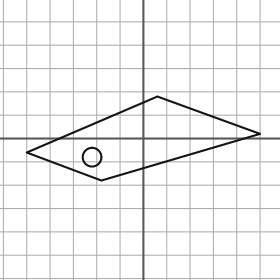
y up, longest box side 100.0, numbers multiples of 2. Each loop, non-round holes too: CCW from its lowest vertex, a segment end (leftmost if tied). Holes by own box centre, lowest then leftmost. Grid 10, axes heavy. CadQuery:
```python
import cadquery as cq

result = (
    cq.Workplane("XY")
    .moveTo(-18.0, -18.0)
    .lineTo(50.0, 2.0)
    .lineTo(6.0, 18.0)
    .lineTo(-50.0, -6.0)
    .close()
    .moveTo(-22.0, -8.0)
    .circle(4.0)
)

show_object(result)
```